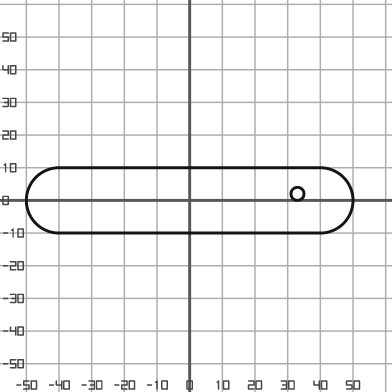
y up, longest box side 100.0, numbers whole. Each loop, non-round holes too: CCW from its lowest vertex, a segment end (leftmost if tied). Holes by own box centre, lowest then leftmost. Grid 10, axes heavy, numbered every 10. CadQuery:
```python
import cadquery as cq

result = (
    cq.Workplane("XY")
    .moveTo(-40.0, -10.0)
    .lineTo(40.0, -10.0)
    .threePointArc((50.0, 0.0), (40.0, 10.0))
    .lineTo(-40.0, 10.0)
    .threePointArc((-50.0, 0.0), (-40.0, -10.0))
    .close()
    .moveTo(33.0, 2.0)
    .circle(2.0)
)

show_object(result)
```